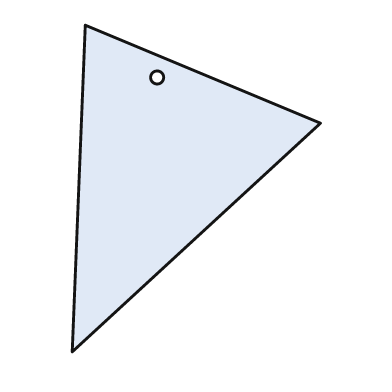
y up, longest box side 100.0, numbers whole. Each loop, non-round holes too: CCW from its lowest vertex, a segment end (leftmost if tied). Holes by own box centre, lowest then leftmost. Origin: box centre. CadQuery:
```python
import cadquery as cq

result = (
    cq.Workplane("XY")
    .moveTo(-38.0, -50.0)
    .lineTo(38.0, 20.0)
    .lineTo(-34.0, 50.0)
    .close()
    .moveTo(-12.0, 34.0)
    .circle(2.0)
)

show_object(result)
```